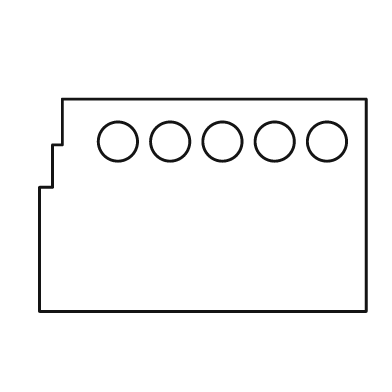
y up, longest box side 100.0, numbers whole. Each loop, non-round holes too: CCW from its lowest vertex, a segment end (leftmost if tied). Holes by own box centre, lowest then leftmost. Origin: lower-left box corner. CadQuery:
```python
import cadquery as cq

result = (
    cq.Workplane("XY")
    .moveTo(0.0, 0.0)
    .lineTo(100.0, 0.0)
    .lineTo(100.0, 65.0)
    .lineTo(7.0, 65.0)
    .lineTo(7.0, 51.0)
    .lineTo(4.0, 51.0)
    .lineTo(4.0, 38.0)
    .lineTo(0.0, 38.0)
    .close()
    .moveTo(24.0, 52.0)
    .circle(6.0)
    .moveTo(40.0, 52.0)
    .circle(6.0)
    .moveTo(56.0, 52.0)
    .circle(6.0)
    .moveTo(72.0, 52.0)
    .circle(6.0)
    .moveTo(88.0, 52.0)
    .circle(6.0)
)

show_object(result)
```